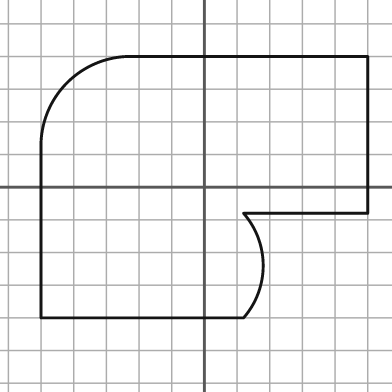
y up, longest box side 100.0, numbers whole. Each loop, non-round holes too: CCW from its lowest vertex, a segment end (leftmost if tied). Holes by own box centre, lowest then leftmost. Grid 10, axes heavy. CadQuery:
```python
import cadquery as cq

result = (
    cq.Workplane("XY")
    .moveTo(-50.0, -40.0)
    .lineTo(12.0, -40.0)
    .threePointArc((18.0, -24.0), (12.0, -8.0))
    .lineTo(50.0, -8.0)
    .lineTo(50.0, 40.0)
    .lineTo(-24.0, 40.0)
    .threePointArc((-42.0, 32.0), (-50.0, 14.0))
    .close()
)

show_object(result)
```